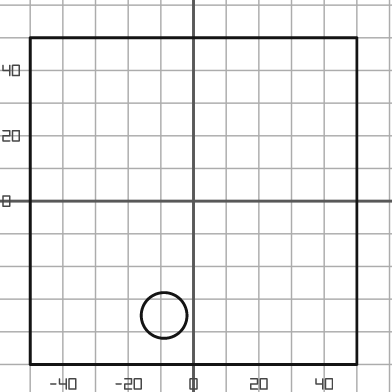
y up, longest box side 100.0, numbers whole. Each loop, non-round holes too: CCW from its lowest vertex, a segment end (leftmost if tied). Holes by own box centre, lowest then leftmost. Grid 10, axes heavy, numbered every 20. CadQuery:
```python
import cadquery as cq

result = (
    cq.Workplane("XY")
    .moveTo(-50.0, -50.0)
    .lineTo(50.0, -50.0)
    .lineTo(50.0, 50.0)
    .lineTo(-50.0, 50.0)
    .close()
    .moveTo(-9.0, -35.0)
    .circle(7.0)
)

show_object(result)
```